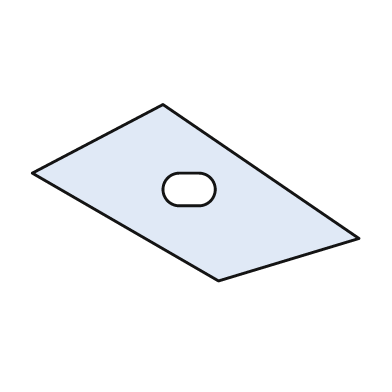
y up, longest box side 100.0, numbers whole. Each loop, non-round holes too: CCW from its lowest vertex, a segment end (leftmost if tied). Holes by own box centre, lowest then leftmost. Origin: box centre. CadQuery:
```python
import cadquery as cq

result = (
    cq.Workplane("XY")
    .moveTo(7.0, -27.0)
    .lineTo(50.0, -14.0)
    .lineTo(-10.0, 27.0)
    .lineTo(-50.0, 6.0)
    .close()
    .moveTo(-5.0, -4.0)
    .lineTo(1.0, -4.0)
    .threePointArc((6.0, 1.0), (1.0, 6.0))
    .lineTo(-5.0, 6.0)
    .threePointArc((-10.0, 1.0), (-5.0, -4.0))
    .close()
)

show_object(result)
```